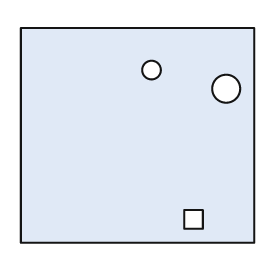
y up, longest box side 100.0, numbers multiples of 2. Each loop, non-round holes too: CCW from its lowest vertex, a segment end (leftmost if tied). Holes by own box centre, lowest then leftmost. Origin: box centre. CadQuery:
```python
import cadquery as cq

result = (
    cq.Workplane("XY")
    .moveTo(-50.0, -46.0)
    .lineTo(50.0, -46.0)
    .lineTo(50.0, 46.0)
    .lineTo(-50.0, 46.0)
    .close()
    .moveTo(20.0, -40.0)
    .lineTo(28.0, -40.0)
    .lineTo(28.0, -32.0)
    .lineTo(20.0, -32.0)
    .close()
    .moveTo(38.0, 20.0)
    .circle(6.0)
    .moveTo(6.0, 28.0)
    .circle(4.0)
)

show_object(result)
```